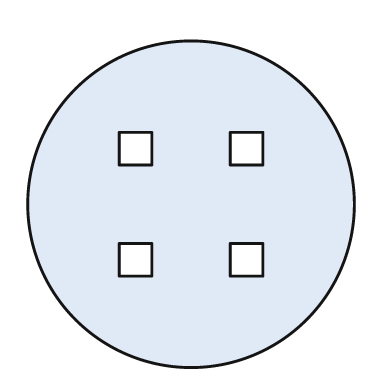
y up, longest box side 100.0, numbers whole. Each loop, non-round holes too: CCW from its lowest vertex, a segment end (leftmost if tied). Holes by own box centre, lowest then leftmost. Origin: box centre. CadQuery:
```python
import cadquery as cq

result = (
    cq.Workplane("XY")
    .moveTo(0.0, 0.0)
    .circle(50.0)
    .moveTo(-22.0, -22.0)
    .lineTo(-12.0, -22.0)
    .lineTo(-12.0, -12.0)
    .lineTo(-22.0, -12.0)
    .close()
    .moveTo(12.0, -22.0)
    .lineTo(22.0, -22.0)
    .lineTo(22.0, -12.0)
    .lineTo(12.0, -12.0)
    .close()
    .moveTo(-22.0, 12.0)
    .lineTo(-12.0, 12.0)
    .lineTo(-12.0, 22.0)
    .lineTo(-22.0, 22.0)
    .close()
    .moveTo(12.0, 12.0)
    .lineTo(22.0, 12.0)
    .lineTo(22.0, 22.0)
    .lineTo(12.0, 22.0)
    .close()
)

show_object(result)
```